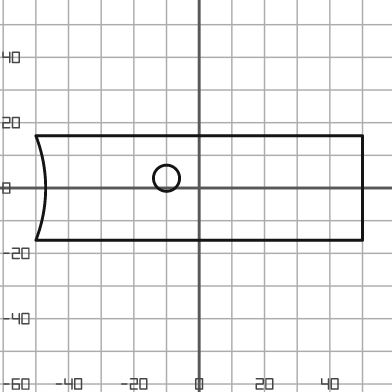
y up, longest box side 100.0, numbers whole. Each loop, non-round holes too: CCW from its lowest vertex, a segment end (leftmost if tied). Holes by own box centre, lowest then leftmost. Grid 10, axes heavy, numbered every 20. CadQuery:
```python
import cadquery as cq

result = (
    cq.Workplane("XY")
    .moveTo(-50.0, -16.0)
    .lineTo(50.0, -16.0)
    .lineTo(50.0, 16.0)
    .lineTo(-50.0, 16.0)
    .threePointArc((-47.0, 0.0), (-50.0, -16.0))
    .close()
    .moveTo(-10.0, 3.0)
    .circle(4.0)
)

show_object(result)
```